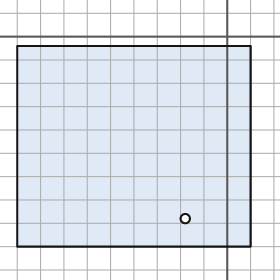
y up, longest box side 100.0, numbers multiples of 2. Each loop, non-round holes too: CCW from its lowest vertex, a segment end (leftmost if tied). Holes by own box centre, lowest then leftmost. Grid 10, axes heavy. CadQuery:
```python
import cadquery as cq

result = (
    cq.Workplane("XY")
    .moveTo(-90.0, -90.0)
    .lineTo(10.0, -90.0)
    .lineTo(10.0, -4.0)
    .lineTo(-90.0, -4.0)
    .close()
    .moveTo(-18.0, -78.0)
    .circle(2.0)
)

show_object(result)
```